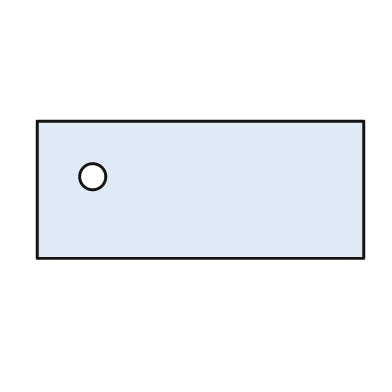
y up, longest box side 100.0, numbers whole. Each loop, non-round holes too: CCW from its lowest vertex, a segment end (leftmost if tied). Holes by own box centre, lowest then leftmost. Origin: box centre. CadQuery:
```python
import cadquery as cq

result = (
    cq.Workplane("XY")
    .moveTo(-50.0, -21.0)
    .lineTo(50.0, -21.0)
    .lineTo(50.0, 21.0)
    .lineTo(-50.0, 21.0)
    .close()
    .moveTo(-33.0, 4.0)
    .circle(4.0)
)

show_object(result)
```